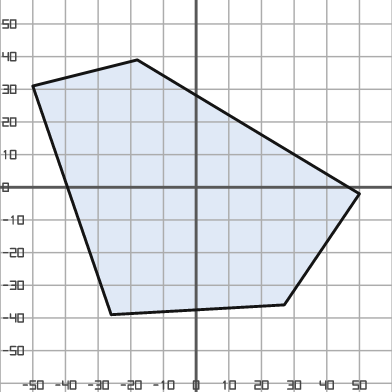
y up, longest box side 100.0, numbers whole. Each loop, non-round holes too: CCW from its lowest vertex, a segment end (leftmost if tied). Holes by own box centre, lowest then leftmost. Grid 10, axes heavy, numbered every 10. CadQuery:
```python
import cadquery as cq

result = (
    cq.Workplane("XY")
    .moveTo(-26.0, -39.0)
    .lineTo(27.0, -36.0)
    .lineTo(50.0, -2.0)
    .lineTo(-18.0, 39.0)
    .lineTo(-50.0, 31.0)
    .close()
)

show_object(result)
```